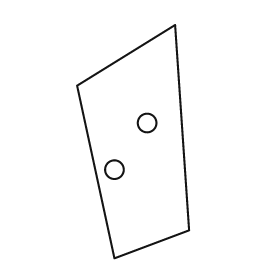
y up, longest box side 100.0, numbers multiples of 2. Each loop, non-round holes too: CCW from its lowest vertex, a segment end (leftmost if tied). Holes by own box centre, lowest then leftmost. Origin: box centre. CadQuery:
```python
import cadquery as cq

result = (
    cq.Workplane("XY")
    .moveTo(-8.0, -50.0)
    .lineTo(24.0, -38.0)
    .lineTo(18.0, 50.0)
    .lineTo(-24.0, 24.0)
    .close()
    .moveTo(-8.0, -12.0)
    .circle(4.0)
    .moveTo(6.0, 8.0)
    .circle(4.0)
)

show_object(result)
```